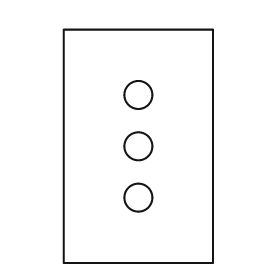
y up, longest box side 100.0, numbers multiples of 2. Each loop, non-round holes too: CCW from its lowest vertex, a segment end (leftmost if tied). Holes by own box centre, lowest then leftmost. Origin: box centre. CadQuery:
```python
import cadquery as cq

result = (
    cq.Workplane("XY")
    .moveTo(-32.0, -50.0)
    .lineTo(32.0, -50.0)
    .lineTo(32.0, 50.0)
    .lineTo(-32.0, 50.0)
    .close()
    .moveTo(0.0, -22.0)
    .circle(6.0)
    .moveTo(0.0, 0.0)
    .circle(6.0)
    .moveTo(0.0, 22.0)
    .circle(6.0)
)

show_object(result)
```